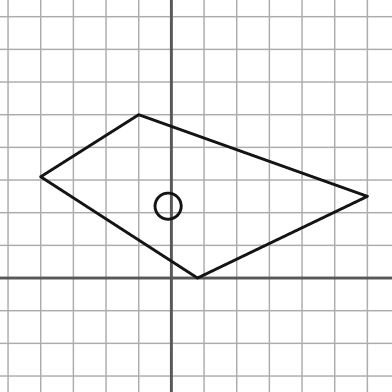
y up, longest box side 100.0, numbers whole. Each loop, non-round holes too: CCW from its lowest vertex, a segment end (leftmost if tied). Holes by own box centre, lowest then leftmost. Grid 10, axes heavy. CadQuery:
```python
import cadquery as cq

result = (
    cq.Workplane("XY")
    .moveTo(8.0, 0.0)
    .lineTo(60.0, 25.0)
    .lineTo(-10.0, 50.0)
    .lineTo(-40.0, 31.0)
    .close()
    .moveTo(-1.0, 22.0)
    .circle(4.0)
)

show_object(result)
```